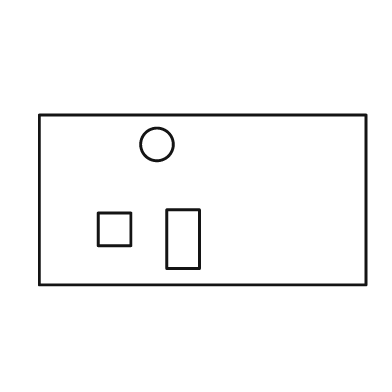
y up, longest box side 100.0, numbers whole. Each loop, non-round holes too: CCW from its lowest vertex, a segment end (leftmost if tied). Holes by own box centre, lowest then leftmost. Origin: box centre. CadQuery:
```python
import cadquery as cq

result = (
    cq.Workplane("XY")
    .moveTo(-50.0, -26.0)
    .lineTo(50.0, -26.0)
    .lineTo(50.0, 26.0)
    .lineTo(-50.0, 26.0)
    .close()
    .moveTo(-11.0, -21.0)
    .lineTo(-1.0, -21.0)
    .lineTo(-1.0, -3.0)
    .lineTo(-11.0, -3.0)
    .close()
    .moveTo(-32.0, -14.0)
    .lineTo(-22.0, -14.0)
    .lineTo(-22.0, -4.0)
    .lineTo(-32.0, -4.0)
    .close()
    .moveTo(-14.0, 17.0)
    .circle(5.0)
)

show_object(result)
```